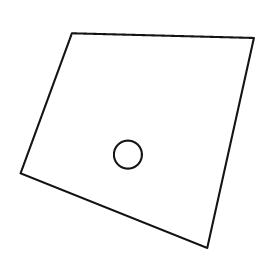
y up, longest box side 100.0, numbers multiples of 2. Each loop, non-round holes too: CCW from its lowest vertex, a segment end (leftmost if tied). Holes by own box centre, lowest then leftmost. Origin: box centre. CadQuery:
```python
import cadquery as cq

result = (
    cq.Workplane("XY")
    .moveTo(30.0, -46.0)
    .lineTo(50.0, 44.0)
    .lineTo(-28.0, 46.0)
    .lineTo(-50.0, -14.0)
    .close()
    .moveTo(-4.0, -6.0)
    .circle(6.0)
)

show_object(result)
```